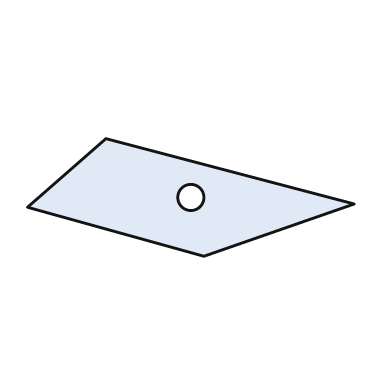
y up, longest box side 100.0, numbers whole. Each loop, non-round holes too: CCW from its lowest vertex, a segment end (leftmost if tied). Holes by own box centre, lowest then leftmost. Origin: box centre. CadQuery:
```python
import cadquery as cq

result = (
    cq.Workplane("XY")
    .moveTo(4.0, -18.0)
    .lineTo(50.0, -2.0)
    .lineTo(-26.0, 18.0)
    .lineTo(-50.0, -3.0)
    .close()
    .moveTo(0.0, 0.0)
    .circle(4.0)
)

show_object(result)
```